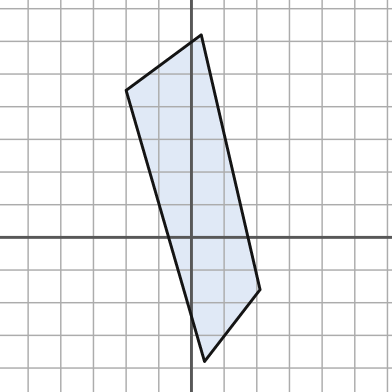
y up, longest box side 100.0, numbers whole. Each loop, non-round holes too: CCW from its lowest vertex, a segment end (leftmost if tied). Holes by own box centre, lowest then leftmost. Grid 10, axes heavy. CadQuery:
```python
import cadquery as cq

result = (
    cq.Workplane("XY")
    .moveTo(4.0, -38.0)
    .lineTo(21.0, -16.0)
    .lineTo(3.0, 62.0)
    .lineTo(-20.0, 45.0)
    .close()
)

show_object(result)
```